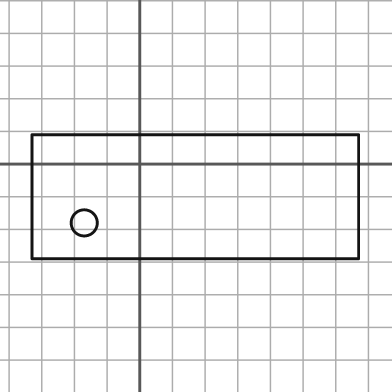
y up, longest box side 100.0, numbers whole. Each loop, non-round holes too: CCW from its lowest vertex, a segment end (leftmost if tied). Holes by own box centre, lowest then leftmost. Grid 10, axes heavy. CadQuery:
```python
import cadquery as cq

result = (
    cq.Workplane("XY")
    .moveTo(-33.0, -29.0)
    .lineTo(67.0, -29.0)
    .lineTo(67.0, 9.0)
    .lineTo(-33.0, 9.0)
    .close()
    .moveTo(-17.0, -18.0)
    .circle(4.0)
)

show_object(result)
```